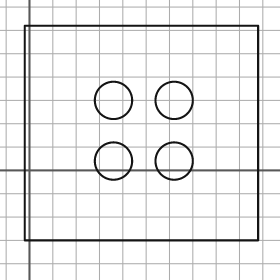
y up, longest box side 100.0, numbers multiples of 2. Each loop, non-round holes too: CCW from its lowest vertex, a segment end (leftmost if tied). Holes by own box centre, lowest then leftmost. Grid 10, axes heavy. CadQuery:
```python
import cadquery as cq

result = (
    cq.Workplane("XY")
    .moveTo(-2.0, -30.0)
    .lineTo(98.0, -30.0)
    .lineTo(98.0, 62.0)
    .lineTo(-2.0, 62.0)
    .close()
    .moveTo(36.0, 4.0)
    .circle(8.0)
    .moveTo(62.0, 4.0)
    .circle(8.0)
    .moveTo(36.0, 30.0)
    .circle(8.0)
    .moveTo(62.0, 30.0)
    .circle(8.0)
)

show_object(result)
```